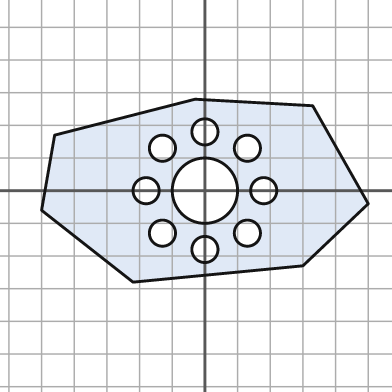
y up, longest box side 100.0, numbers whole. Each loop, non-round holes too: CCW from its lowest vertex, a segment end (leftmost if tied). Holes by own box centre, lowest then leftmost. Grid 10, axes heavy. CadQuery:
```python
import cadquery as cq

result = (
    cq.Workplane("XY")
    .moveTo(-22.0, -28.0)
    .lineTo(30.0, -23.0)
    .lineTo(50.0, -4.0)
    .lineTo(33.0, 26.0)
    .lineTo(-3.0, 28.0)
    .lineTo(-46.0, 17.0)
    .lineTo(-50.0, -6.0)
    .close()
    .moveTo(0.0, -18.0)
    .circle(4.0)
    .moveTo(-13.0, -13.0)
    .circle(4.0)
    .moveTo(13.0, -13.0)
    .circle(4.0)
    .moveTo(-18.0, 0.0)
    .circle(4.0)
    .moveTo(0.0, 0.0)
    .circle(10.0)
    .moveTo(18.0, 0.0)
    .circle(4.0)
    .moveTo(-13.0, 13.0)
    .circle(4.0)
    .moveTo(13.0, 13.0)
    .circle(4.0)
    .moveTo(0.0, 18.0)
    .circle(4.0)
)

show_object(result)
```